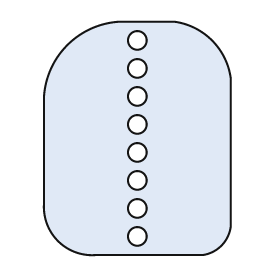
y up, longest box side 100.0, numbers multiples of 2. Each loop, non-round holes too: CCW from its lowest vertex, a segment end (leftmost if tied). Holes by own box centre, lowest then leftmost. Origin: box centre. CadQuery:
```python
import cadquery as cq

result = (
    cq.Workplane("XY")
    .moveTo(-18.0, -50.0)
    .lineTo(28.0, -50.0)
    .threePointArc((36.0, -46.0), (40.0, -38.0))
    .lineTo(40.0, 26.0)
    .threePointArc((32.0, 42.0), (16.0, 50.0))
    .lineTo(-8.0, 50.0)
    .threePointArc((-30.0, 40.0), (-40.0, 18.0))
    .lineTo(-40.0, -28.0)
    .threePointArc((-34.0, -44.0), (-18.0, -50.0))
    .close()
    .moveTo(0.0, -42.0)
    .circle(4.0)
    .moveTo(0.0, -30.0)
    .circle(4.0)
    .moveTo(0.0, -18.0)
    .circle(4.0)
    .moveTo(0.0, -6.0)
    .circle(4.0)
    .moveTo(0.0, 6.0)
    .circle(4.0)
    .moveTo(0.0, 18.0)
    .circle(4.0)
    .moveTo(0.0, 30.0)
    .circle(4.0)
    .moveTo(0.0, 42.0)
    .circle(4.0)
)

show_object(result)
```